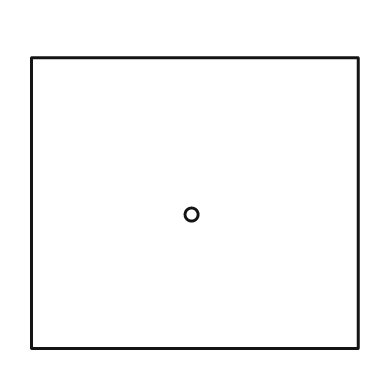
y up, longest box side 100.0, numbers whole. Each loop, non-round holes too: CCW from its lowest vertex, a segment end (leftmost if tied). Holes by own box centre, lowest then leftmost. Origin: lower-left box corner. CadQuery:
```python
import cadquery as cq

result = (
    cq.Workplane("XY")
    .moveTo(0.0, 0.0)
    .lineTo(100.0, 0.0)
    .lineTo(100.0, 89.0)
    .lineTo(0.0, 89.0)
    .close()
    .moveTo(49.0, 41.0)
    .circle(2.0)
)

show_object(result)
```